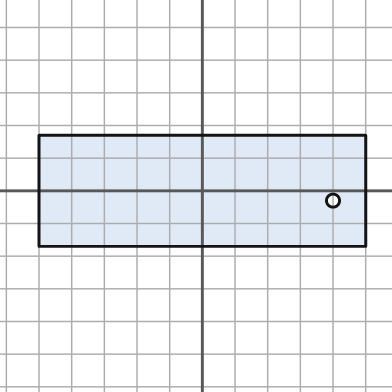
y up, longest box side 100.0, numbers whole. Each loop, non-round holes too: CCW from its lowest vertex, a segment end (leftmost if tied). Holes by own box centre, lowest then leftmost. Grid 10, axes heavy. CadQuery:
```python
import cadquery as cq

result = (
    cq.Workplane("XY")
    .moveTo(-50.0, -17.0)
    .lineTo(50.0, -17.0)
    .lineTo(50.0, 17.0)
    .lineTo(-50.0, 17.0)
    .close()
    .moveTo(40.0, -3.0)
    .circle(2.0)
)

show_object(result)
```